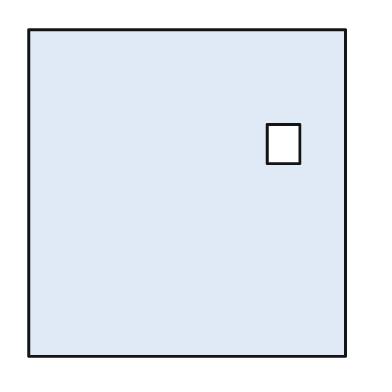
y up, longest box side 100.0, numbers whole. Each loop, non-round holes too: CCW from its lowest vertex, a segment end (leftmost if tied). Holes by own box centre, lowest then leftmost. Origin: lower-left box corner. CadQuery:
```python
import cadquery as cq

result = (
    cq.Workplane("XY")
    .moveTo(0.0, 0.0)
    .lineTo(97.0, 0.0)
    .lineTo(97.0, 100.0)
    .lineTo(0.0, 100.0)
    .close()
    .moveTo(73.0, 59.0)
    .lineTo(83.0, 59.0)
    .lineTo(83.0, 71.0)
    .lineTo(73.0, 71.0)
    .close()
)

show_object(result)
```